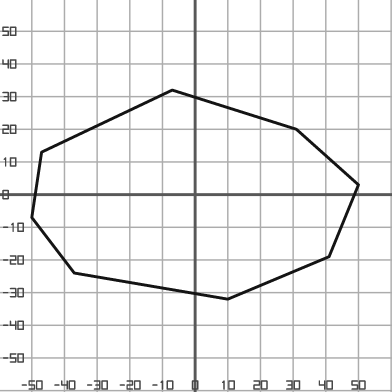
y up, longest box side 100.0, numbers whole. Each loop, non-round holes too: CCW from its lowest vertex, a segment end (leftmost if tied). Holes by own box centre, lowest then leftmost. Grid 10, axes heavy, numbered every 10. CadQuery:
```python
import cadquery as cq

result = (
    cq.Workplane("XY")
    .moveTo(10.0, -32.0)
    .lineTo(41.0, -19.0)
    .lineTo(50.0, 3.0)
    .lineTo(31.0, 20.0)
    .lineTo(-7.0, 32.0)
    .lineTo(-47.0, 13.0)
    .lineTo(-50.0, -7.0)
    .lineTo(-37.0, -24.0)
    .close()
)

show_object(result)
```